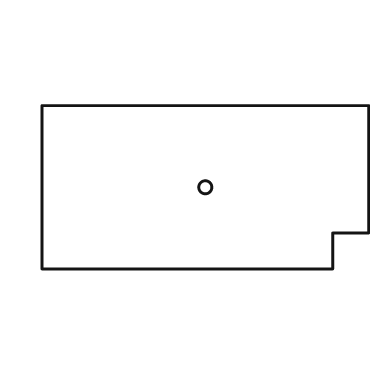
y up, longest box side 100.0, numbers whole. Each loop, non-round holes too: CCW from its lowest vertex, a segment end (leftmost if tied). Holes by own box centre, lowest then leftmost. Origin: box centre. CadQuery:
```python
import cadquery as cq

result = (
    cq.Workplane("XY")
    .moveTo(-50.0, -25.0)
    .lineTo(39.0, -25.0)
    .lineTo(39.0, -14.0)
    .lineTo(50.0, -14.0)
    .lineTo(50.0, 25.0)
    .lineTo(-50.0, 25.0)
    .close()
    .moveTo(0.0, 0.0)
    .circle(2.0)
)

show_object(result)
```